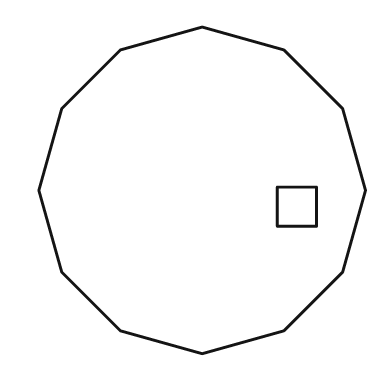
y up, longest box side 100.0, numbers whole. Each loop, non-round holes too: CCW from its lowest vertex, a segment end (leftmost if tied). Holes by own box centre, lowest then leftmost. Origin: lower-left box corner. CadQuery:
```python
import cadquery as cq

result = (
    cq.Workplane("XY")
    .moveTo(50.0, 0.0)
    .lineTo(75.0, 7.0)
    .lineTo(93.0, 25.0)
    .lineTo(100.0, 50.0)
    .lineTo(93.0, 75.0)
    .lineTo(75.0, 93.0)
    .lineTo(50.0, 100.0)
    .lineTo(25.0, 93.0)
    .lineTo(7.0, 75.0)
    .lineTo(0.0, 50.0)
    .lineTo(7.0, 25.0)
    .lineTo(25.0, 7.0)
    .close()
    .moveTo(73.0, 39.0)
    .lineTo(85.0, 39.0)
    .lineTo(85.0, 51.0)
    .lineTo(73.0, 51.0)
    .close()
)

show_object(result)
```